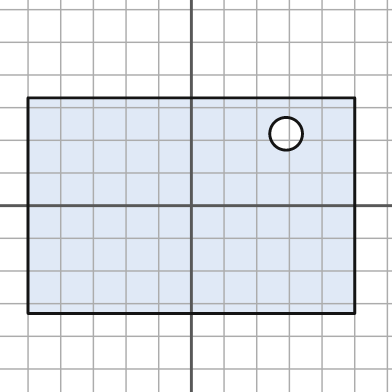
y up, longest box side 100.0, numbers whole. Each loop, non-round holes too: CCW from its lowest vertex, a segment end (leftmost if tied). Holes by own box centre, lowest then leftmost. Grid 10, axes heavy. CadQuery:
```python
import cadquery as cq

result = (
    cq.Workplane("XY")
    .moveTo(-50.0, -33.0)
    .lineTo(50.0, -33.0)
    .lineTo(50.0, 33.0)
    .lineTo(-50.0, 33.0)
    .close()
    .moveTo(29.0, 22.0)
    .circle(5.0)
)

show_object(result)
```